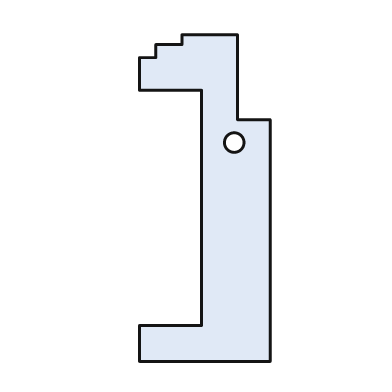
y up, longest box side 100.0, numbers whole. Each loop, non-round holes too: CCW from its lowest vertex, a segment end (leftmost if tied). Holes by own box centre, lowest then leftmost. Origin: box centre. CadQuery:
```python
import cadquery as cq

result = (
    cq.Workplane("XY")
    .moveTo(-20.0, -50.0)
    .lineTo(20.0, -50.0)
    .lineTo(20.0, 24.0)
    .lineTo(10.0, 24.0)
    .lineTo(10.0, 50.0)
    .lineTo(-7.0, 50.0)
    .lineTo(-7.0, 47.0)
    .lineTo(-15.0, 47.0)
    .lineTo(-15.0, 43.0)
    .lineTo(-20.0, 43.0)
    .lineTo(-20.0, 33.0)
    .lineTo(-1.0, 33.0)
    .lineTo(-1.0, -39.0)
    .lineTo(-20.0, -39.0)
    .close()
    .moveTo(9.0, 17.0)
    .circle(3.0)
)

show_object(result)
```